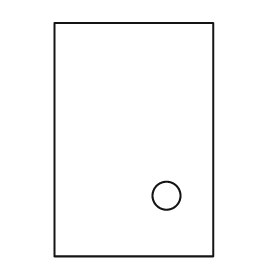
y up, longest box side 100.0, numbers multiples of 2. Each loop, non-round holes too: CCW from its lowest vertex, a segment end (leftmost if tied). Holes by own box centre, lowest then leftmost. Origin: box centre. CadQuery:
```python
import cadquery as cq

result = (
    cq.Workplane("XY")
    .moveTo(-34.0, -50.0)
    .lineTo(34.0, -50.0)
    .lineTo(34.0, 50.0)
    .lineTo(-34.0, 50.0)
    .close()
    .moveTo(14.0, -24.0)
    .circle(6.0)
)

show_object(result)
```